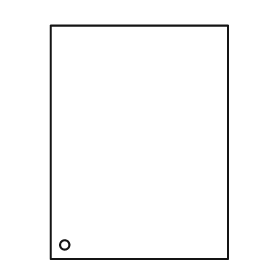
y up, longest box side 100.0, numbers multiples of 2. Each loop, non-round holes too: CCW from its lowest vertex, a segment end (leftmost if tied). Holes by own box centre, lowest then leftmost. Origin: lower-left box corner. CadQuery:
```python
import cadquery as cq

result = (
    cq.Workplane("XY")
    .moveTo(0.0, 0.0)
    .lineTo(76.0, 0.0)
    .lineTo(76.0, 100.0)
    .lineTo(0.0, 100.0)
    .close()
    .moveTo(6.0, 6.0)
    .circle(2.0)
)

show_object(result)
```